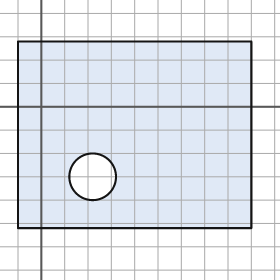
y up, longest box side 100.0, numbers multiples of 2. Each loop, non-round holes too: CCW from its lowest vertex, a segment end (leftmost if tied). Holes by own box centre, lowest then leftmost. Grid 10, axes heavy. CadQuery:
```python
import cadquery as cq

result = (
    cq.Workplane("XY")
    .moveTo(-10.0, -52.0)
    .lineTo(90.0, -52.0)
    .lineTo(90.0, 28.0)
    .lineTo(-10.0, 28.0)
    .close()
    .moveTo(22.0, -30.0)
    .circle(10.0)
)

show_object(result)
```